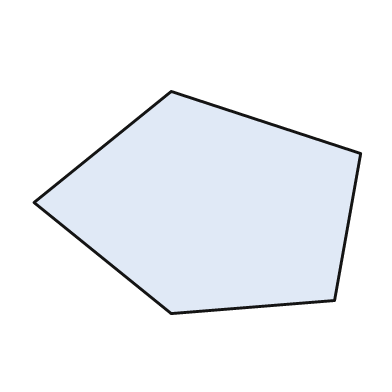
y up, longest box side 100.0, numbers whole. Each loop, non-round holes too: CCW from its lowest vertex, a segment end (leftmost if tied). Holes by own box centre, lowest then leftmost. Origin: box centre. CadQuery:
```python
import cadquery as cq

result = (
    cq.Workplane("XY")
    .moveTo(-8.0, -34.0)
    .lineTo(42.0, -30.0)
    .lineTo(50.0, 15.0)
    .lineTo(-8.0, 34.0)
    .lineTo(-50.0, 0.0)
    .close()
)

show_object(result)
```